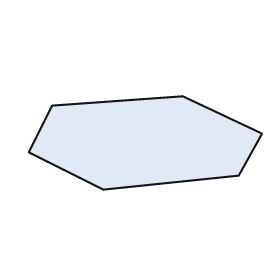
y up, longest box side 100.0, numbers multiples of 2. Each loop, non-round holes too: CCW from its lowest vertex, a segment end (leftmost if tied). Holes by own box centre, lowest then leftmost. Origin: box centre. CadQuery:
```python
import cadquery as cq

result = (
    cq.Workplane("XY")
    .moveTo(-18.0, -20.0)
    .lineTo(40.0, -14.0)
    .lineTo(50.0, 4.0)
    .lineTo(16.0, 20.0)
    .lineTo(-40.0, 16.0)
    .lineTo(-50.0, -4.0)
    .close()
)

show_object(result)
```